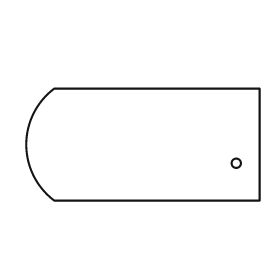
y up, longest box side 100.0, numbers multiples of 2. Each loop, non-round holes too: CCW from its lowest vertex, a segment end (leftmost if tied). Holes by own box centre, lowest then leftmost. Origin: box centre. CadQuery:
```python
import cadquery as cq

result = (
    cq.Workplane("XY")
    .moveTo(-38.0, -24.0)
    .lineTo(50.0, -24.0)
    .lineTo(50.0, 24.0)
    .lineTo(-38.0, 24.0)
    .threePointArc((-50.0, 0.0), (-38.0, -24.0))
    .close()
    .moveTo(40.0, -8.0)
    .circle(2.0)
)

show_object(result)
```